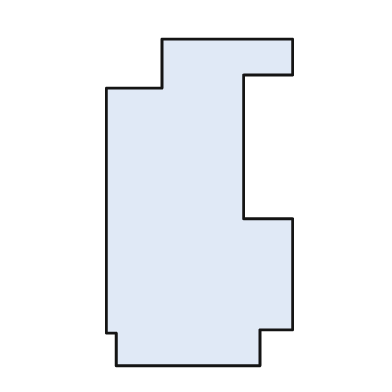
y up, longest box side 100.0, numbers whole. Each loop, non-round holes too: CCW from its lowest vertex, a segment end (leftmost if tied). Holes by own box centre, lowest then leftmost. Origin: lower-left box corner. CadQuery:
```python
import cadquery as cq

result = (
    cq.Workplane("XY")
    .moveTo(3.0, 0.0)
    .lineTo(47.0, 0.0)
    .lineTo(47.0, 11.0)
    .lineTo(57.0, 11.0)
    .lineTo(57.0, 45.0)
    .lineTo(42.0, 45.0)
    .lineTo(42.0, 89.0)
    .lineTo(57.0, 89.0)
    .lineTo(57.0, 100.0)
    .lineTo(17.0, 100.0)
    .lineTo(17.0, 85.0)
    .lineTo(0.0, 85.0)
    .lineTo(0.0, 10.0)
    .lineTo(3.0, 10.0)
    .close()
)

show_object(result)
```